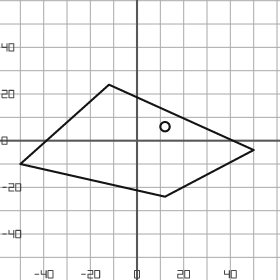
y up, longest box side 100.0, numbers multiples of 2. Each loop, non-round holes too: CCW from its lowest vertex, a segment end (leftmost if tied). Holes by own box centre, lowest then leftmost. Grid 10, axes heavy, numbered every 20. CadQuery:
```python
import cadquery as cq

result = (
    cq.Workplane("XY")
    .moveTo(12.0, -24.0)
    .lineTo(50.0, -4.0)
    .lineTo(-12.0, 24.0)
    .lineTo(-50.0, -10.0)
    .close()
    .moveTo(12.0, 6.0)
    .circle(2.0)
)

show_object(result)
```